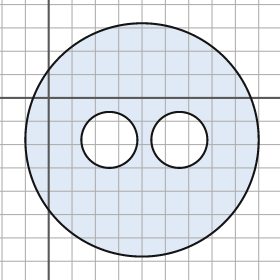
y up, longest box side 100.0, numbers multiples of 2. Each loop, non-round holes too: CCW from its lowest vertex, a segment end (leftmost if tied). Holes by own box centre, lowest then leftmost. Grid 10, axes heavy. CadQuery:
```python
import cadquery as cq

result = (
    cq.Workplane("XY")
    .moveTo(40.0, -18.0)
    .circle(50.0)
    .moveTo(26.0, -18.0)
    .circle(12.0)
    .moveTo(56.0, -18.0)
    .circle(12.0)
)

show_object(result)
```